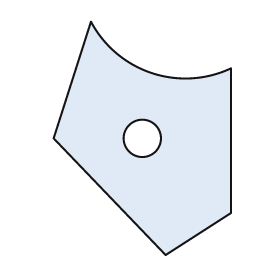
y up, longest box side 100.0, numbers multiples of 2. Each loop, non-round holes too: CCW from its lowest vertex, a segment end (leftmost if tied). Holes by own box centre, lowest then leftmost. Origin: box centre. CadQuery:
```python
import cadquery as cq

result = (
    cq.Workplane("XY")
    .moveTo(10.0, -50.0)
    .lineTo(38.0, -32.0)
    .lineTo(38.0, 30.0)
    .threePointArc((4.0, 28.0), (-22.0, 50.0))
    .lineTo(-38.0, 0.0)
    .close()
    .moveTo(0.0, 0.0)
    .circle(8.0)
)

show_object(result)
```